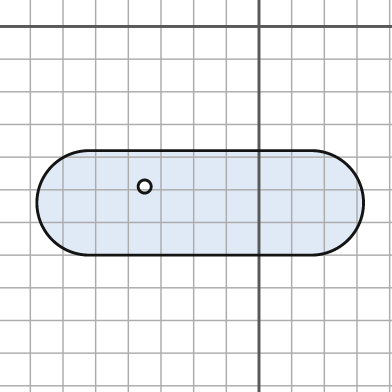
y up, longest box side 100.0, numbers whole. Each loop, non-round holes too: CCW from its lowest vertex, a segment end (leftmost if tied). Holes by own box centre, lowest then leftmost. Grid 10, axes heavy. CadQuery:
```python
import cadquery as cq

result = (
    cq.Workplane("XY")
    .moveTo(-52.0, -70.0)
    .lineTo(16.0, -70.0)
    .threePointArc((32.0, -54.0), (16.0, -38.0))
    .lineTo(-52.0, -38.0)
    .threePointArc((-68.0, -54.0), (-52.0, -70.0))
    .close()
    .moveTo(-35.0, -49.0)
    .circle(2.0)
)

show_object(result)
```